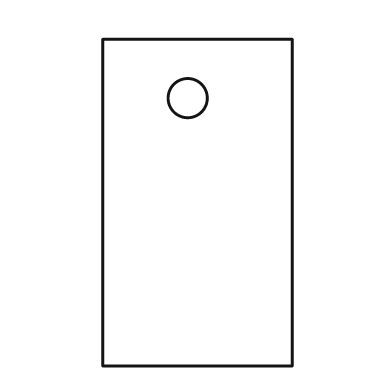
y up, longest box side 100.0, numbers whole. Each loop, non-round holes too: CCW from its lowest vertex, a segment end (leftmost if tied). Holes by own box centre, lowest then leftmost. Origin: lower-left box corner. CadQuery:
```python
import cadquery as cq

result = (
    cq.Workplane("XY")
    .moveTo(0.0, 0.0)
    .lineTo(58.0, 0.0)
    .lineTo(58.0, 100.0)
    .lineTo(0.0, 100.0)
    .close()
    .moveTo(26.0, 82.0)
    .circle(6.0)
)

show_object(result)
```